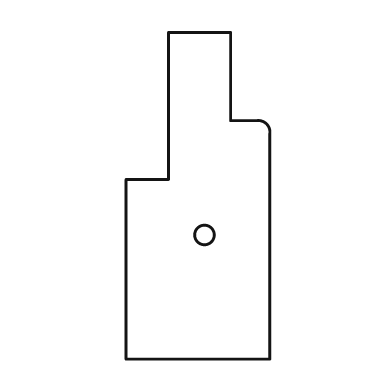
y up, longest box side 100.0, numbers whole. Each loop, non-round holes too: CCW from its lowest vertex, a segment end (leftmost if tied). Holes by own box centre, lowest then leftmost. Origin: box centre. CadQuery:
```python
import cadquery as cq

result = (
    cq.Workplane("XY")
    .moveTo(-22.0, -50.0)
    .lineTo(22.0, -50.0)
    .lineTo(22.0, 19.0)
    .threePointArc((21.0, 22.0), (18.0, 23.0))
    .lineTo(10.0, 23.0)
    .lineTo(10.0, 50.0)
    .lineTo(-9.0, 50.0)
    .lineTo(-9.0, 5.0)
    .lineTo(-22.0, 5.0)
    .close()
    .moveTo(2.0, -12.0)
    .circle(3.0)
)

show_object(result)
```